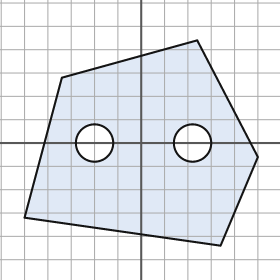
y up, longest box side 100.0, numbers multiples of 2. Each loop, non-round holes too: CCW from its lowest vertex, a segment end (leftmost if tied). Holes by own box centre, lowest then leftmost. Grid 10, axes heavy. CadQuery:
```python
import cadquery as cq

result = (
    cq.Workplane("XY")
    .moveTo(34.0, -44.0)
    .lineTo(50.0, -6.0)
    .lineTo(24.0, 44.0)
    .lineTo(-34.0, 28.0)
    .lineTo(-50.0, -32.0)
    .close()
    .moveTo(-20.0, 0.0)
    .circle(8.0)
    .moveTo(22.0, 0.0)
    .circle(8.0)
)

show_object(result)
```